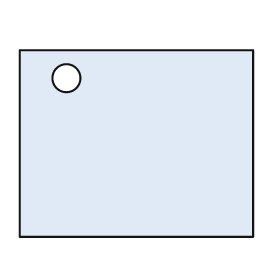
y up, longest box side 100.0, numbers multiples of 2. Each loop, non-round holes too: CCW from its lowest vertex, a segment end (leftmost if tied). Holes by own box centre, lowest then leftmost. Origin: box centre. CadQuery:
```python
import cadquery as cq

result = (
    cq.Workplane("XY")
    .moveTo(-50.0, -40.0)
    .lineTo(50.0, -40.0)
    .lineTo(50.0, 40.0)
    .lineTo(-50.0, 40.0)
    .close()
    .moveTo(-30.0, 28.0)
    .circle(6.0)
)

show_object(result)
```